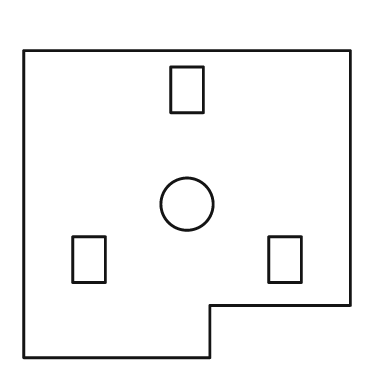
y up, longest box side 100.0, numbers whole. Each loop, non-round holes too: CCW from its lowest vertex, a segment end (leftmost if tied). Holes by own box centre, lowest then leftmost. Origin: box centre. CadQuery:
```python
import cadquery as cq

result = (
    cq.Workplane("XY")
    .moveTo(-50.0, -47.0)
    .lineTo(7.0, -47.0)
    .lineTo(7.0, -31.0)
    .lineTo(50.0, -31.0)
    .lineTo(50.0, 47.0)
    .lineTo(-50.0, 47.0)
    .close()
    .moveTo(-35.0, -24.0)
    .lineTo(-25.0, -24.0)
    .lineTo(-25.0, -10.0)
    .lineTo(-35.0, -10.0)
    .close()
    .moveTo(25.0, -24.0)
    .lineTo(35.0, -24.0)
    .lineTo(35.0, -10.0)
    .lineTo(25.0, -10.0)
    .close()
    .moveTo(0.0, 0.0)
    .circle(8.0)
    .moveTo(-5.0, 28.0)
    .lineTo(5.0, 28.0)
    .lineTo(5.0, 42.0)
    .lineTo(-5.0, 42.0)
    .close()
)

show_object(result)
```